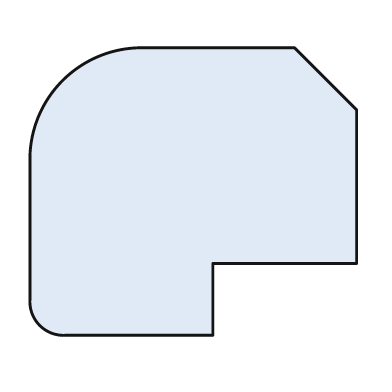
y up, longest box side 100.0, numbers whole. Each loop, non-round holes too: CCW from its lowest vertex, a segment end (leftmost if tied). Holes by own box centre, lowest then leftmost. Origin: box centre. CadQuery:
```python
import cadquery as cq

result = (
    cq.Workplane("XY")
    .moveTo(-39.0, -44.0)
    .lineTo(6.0, -44.0)
    .lineTo(6.0, -22.0)
    .lineTo(50.0, -22.0)
    .lineTo(50.0, 25.0)
    .lineTo(31.0, 44.0)
    .lineTo(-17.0, 44.0)
    .threePointArc((-40.0, 34.0), (-50.0, 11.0))
    .lineTo(-50.0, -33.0)
    .threePointArc((-47.0, -41.0), (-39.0, -44.0))
    .close()
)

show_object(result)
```